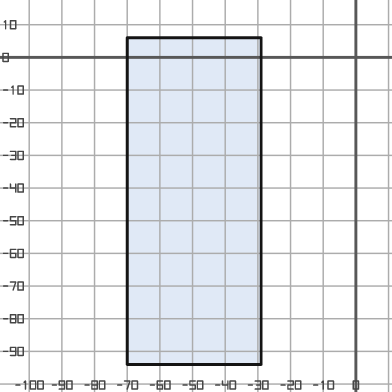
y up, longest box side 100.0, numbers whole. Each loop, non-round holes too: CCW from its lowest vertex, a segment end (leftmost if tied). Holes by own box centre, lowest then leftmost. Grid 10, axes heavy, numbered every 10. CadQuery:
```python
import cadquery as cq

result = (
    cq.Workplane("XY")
    .moveTo(-70.0, -94.0)
    .lineTo(-29.0, -94.0)
    .lineTo(-29.0, 6.0)
    .lineTo(-70.0, 6.0)
    .close()
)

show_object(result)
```